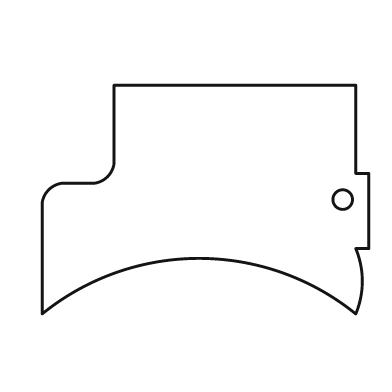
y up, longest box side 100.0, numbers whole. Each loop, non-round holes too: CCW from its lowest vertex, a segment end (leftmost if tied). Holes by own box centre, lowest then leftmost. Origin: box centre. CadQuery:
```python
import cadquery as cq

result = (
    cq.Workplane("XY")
    .moveTo(-50.0, -35.0)
    .threePointArc((-2.0, -18.0), (46.0, -35.0))
    .threePointArc((48.0, -25.0), (46.0, -15.0))
    .lineTo(50.0, -15.0)
    .lineTo(50.0, 8.0)
    .lineTo(46.0, 8.0)
    .lineTo(46.0, 35.0)
    .lineTo(-28.0, 35.0)
    .lineTo(-28.0, 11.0)
    .threePointArc((-30.0, 7.0), (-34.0, 5.0))
    .lineTo(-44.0, 5.0)
    .threePointArc((-48.0, 3.0), (-50.0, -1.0))
    .close()
    .moveTo(42.0, 0.0)
    .circle(3.0)
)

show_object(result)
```